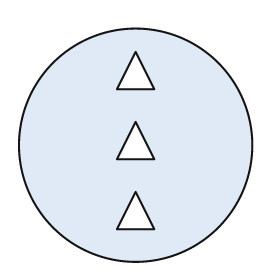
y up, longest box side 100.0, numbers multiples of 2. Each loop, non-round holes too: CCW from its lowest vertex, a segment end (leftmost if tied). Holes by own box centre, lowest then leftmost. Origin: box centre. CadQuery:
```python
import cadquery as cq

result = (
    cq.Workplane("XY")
    .moveTo(0.0, 0.0)
    .circle(50.0)
    .moveTo(-8.0, -36.0)
    .lineTo(8.0, -36.0)
    .lineTo(0.0, -20.0)
    .close()
    .moveTo(-8.0, -6.0)
    .lineTo(8.0, -6.0)
    .lineTo(0.0, 10.0)
    .close()
    .moveTo(-8.0, 24.0)
    .lineTo(8.0, 24.0)
    .lineTo(0.0, 40.0)
    .close()
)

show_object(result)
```